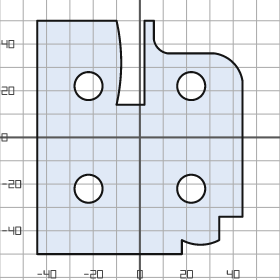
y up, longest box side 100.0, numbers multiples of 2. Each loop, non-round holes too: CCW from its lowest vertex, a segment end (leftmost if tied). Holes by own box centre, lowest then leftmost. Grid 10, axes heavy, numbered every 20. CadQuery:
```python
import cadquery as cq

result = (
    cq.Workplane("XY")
    .moveTo(-44.0, -50.0)
    .lineTo(18.0, -50.0)
    .lineTo(18.0, -44.0)
    .threePointArc((26.0, -46.0), (34.0, -44.0))
    .lineTo(34.0, -34.0)
    .lineTo(44.0, -34.0)
    .lineTo(44.0, 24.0)
    .threePointArc((40.0, 32.0), (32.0, 36.0))
    .lineTo(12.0, 36.0)
    .threePointArc((8.0, 38.0), (6.0, 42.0))
    .lineTo(6.0, 50.0)
    .lineTo(2.0, 50.0)
    .lineTo(2.0, 14.0)
    .lineTo(-10.0, 14.0)
    .threePointArc((-8.0, 32.0), (-10.0, 50.0))
    .lineTo(-44.0, 50.0)
    .close()
    .moveTo(-22.0, -22.0)
    .circle(6.0)
    .moveTo(22.0, -22.0)
    .circle(6.0)
    .moveTo(-22.0, 22.0)
    .circle(6.0)
    .moveTo(22.0, 22.0)
    .circle(6.0)
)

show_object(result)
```